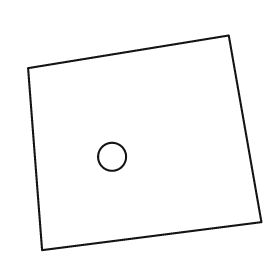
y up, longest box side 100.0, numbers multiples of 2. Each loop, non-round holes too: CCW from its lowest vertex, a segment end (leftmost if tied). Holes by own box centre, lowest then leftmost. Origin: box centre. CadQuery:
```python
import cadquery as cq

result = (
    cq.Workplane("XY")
    .moveTo(-44.0, -46.0)
    .lineTo(50.0, -34.0)
    .lineTo(36.0, 46.0)
    .lineTo(-50.0, 32.0)
    .close()
    .moveTo(-14.0, -6.0)
    .circle(6.0)
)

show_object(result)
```